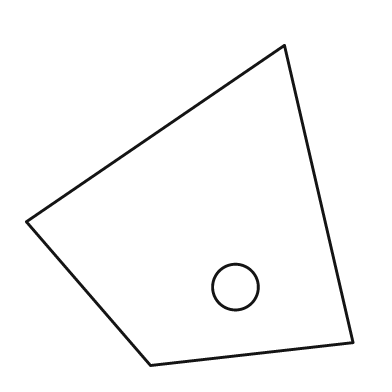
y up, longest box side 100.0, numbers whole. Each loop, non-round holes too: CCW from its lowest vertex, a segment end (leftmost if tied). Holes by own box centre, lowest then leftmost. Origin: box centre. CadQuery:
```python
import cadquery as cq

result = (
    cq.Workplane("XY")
    .moveTo(-12.0, -49.0)
    .lineTo(50.0, -42.0)
    .lineTo(29.0, 49.0)
    .lineTo(-50.0, -5.0)
    .close()
    .moveTo(14.0, -25.0)
    .circle(7.0)
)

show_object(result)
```